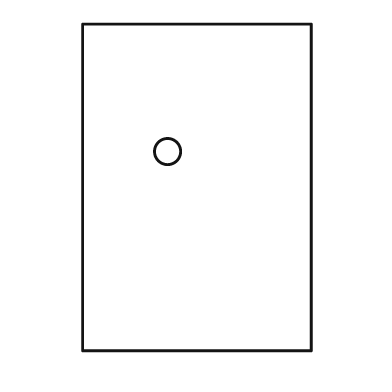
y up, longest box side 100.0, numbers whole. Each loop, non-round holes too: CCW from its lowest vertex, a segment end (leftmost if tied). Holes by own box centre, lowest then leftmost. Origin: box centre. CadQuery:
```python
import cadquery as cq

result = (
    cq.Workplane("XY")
    .moveTo(-35.0, -50.0)
    .lineTo(35.0, -50.0)
    .lineTo(35.0, 50.0)
    .lineTo(-35.0, 50.0)
    .close()
    .moveTo(-9.0, 11.0)
    .circle(4.0)
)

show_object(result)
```